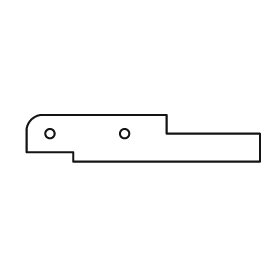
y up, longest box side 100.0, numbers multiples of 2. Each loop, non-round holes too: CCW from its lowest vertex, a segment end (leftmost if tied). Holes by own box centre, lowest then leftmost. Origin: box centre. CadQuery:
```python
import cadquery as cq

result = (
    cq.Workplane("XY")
    .moveTo(-30.0, -10.0)
    .lineTo(50.0, -10.0)
    .lineTo(50.0, 2.0)
    .lineTo(10.0, 2.0)
    .lineTo(10.0, 10.0)
    .lineTo(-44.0, 10.0)
    .threePointArc((-48.0, 8.0), (-50.0, 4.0))
    .lineTo(-50.0, -6.0)
    .lineTo(-30.0, -6.0)
    .close()
    .moveTo(-40.0, 2.0)
    .circle(2.0)
    .moveTo(-8.0, 2.0)
    .circle(2.0)
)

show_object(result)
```